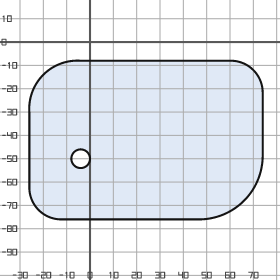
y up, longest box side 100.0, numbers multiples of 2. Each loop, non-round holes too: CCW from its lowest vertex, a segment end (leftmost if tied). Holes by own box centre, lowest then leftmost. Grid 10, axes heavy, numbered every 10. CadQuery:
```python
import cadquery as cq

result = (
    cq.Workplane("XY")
    .moveTo(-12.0, -76.0)
    .lineTo(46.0, -76.0)
    .threePointArc((66.0, -68.0), (74.0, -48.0))
    .lineTo(74.0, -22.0)
    .threePointArc((70.0, -12.0), (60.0, -8.0))
    .lineTo(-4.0, -8.0)
    .threePointArc((-20.0, -14.0), (-26.0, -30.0))
    .lineTo(-26.0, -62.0)
    .threePointArc((-22.0, -72.0), (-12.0, -76.0))
    .close()
    .moveTo(-4.0, -50.0)
    .circle(4.0)
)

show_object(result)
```